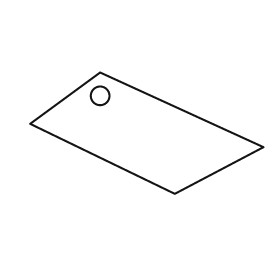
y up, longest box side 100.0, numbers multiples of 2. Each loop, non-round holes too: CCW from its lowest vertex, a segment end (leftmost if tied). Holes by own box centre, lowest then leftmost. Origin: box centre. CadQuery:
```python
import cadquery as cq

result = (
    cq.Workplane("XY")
    .moveTo(12.0, -26.0)
    .lineTo(50.0, -6.0)
    .lineTo(-20.0, 26.0)
    .lineTo(-50.0, 4.0)
    .close()
    .moveTo(-20.0, 16.0)
    .circle(4.0)
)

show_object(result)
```